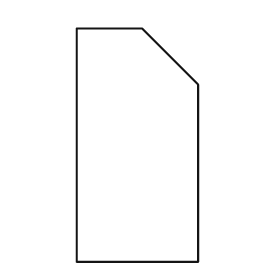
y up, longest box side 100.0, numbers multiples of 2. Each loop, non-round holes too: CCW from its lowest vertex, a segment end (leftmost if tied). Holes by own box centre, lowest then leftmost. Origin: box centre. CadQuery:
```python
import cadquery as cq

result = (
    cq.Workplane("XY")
    .moveTo(-26.0, -50.0)
    .lineTo(26.0, -50.0)
    .lineTo(26.0, 26.0)
    .lineTo(2.0, 50.0)
    .lineTo(-26.0, 50.0)
    .close()
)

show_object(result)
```